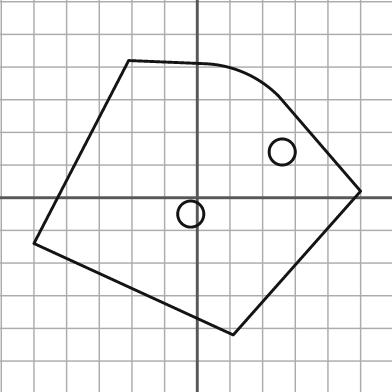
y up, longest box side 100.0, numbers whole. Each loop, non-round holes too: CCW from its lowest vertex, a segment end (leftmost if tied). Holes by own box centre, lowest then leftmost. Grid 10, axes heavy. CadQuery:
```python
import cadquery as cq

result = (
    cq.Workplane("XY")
    .moveTo(11.0, -42.0)
    .lineTo(50.0, 2.0)
    .lineTo(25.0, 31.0)
    .threePointArc((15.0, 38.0), (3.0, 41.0))
    .lineTo(-21.0, 42.0)
    .lineTo(-50.0, -14.0)
    .close()
    .moveTo(-2.0, -5.0)
    .circle(4.0)
    .moveTo(26.0, 14.0)
    .circle(4.0)
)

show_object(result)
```